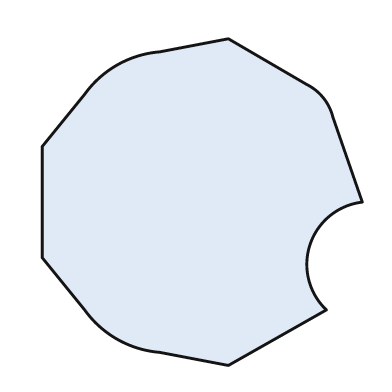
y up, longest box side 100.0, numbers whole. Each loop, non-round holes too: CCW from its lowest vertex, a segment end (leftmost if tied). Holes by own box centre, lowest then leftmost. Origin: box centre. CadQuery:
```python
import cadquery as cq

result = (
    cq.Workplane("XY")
    .moveTo(8.0, -50.0)
    .lineTo(38.0, -33.0)
    .threePointArc((33.0, -13.0), (49.0, 0.0))
    .lineTo(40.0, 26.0)
    .threePointArc((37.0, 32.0), (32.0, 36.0))
    .lineTo(8.0, 50.0)
    .lineTo(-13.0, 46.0)
    .threePointArc((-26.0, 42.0), (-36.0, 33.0))
    .lineTo(-49.0, 17.0)
    .lineTo(-49.0, -17.0)
    .lineTo(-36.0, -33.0)
    .threePointArc((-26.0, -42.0), (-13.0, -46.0))
    .close()
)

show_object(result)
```